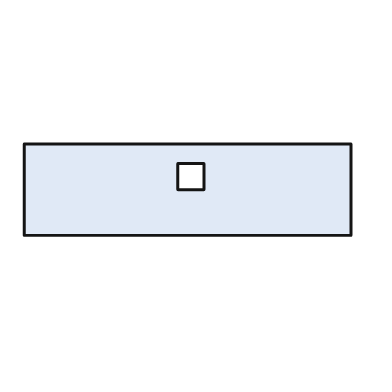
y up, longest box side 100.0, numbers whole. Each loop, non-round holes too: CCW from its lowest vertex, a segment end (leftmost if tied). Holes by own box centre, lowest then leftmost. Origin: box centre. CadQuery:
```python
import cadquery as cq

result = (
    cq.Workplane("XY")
    .moveTo(-50.0, -14.0)
    .lineTo(50.0, -14.0)
    .lineTo(50.0, 14.0)
    .lineTo(-50.0, 14.0)
    .close()
    .moveTo(-3.0, 0.0)
    .lineTo(5.0, 0.0)
    .lineTo(5.0, 8.0)
    .lineTo(-3.0, 8.0)
    .close()
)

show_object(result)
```